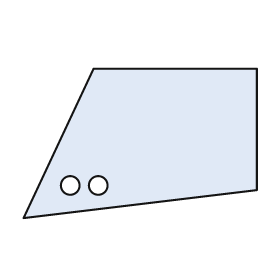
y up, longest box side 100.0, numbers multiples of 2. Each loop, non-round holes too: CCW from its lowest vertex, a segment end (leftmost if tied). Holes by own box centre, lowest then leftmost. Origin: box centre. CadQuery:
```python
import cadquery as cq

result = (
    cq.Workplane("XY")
    .moveTo(-50.0, -32.0)
    .lineTo(50.0, -20.0)
    .lineTo(50.0, 32.0)
    .lineTo(-20.0, 32.0)
    .close()
    .moveTo(-30.0, -18.0)
    .circle(4.0)
    .moveTo(-18.0, -18.0)
    .circle(4.0)
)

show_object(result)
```